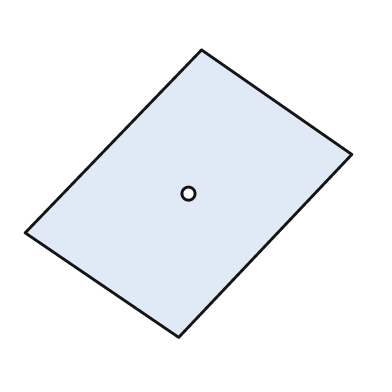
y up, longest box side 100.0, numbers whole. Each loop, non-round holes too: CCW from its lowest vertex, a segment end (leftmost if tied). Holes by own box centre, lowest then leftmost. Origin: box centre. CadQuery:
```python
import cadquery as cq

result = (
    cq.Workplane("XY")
    .moveTo(-3.0, -44.0)
    .lineTo(50.0, 12.0)
    .lineTo(4.0, 44.0)
    .lineTo(-50.0, -12.0)
    .close()
    .moveTo(0.0, 0.0)
    .circle(2.0)
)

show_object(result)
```